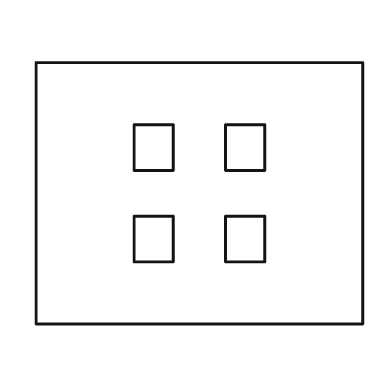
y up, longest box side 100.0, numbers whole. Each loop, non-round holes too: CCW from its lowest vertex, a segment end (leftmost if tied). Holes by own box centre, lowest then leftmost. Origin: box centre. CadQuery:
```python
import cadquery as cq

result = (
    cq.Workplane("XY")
    .moveTo(-50.0, -40.0)
    .lineTo(50.0, -40.0)
    .lineTo(50.0, 40.0)
    .lineTo(-50.0, 40.0)
    .close()
    .moveTo(-20.0, -21.0)
    .lineTo(-8.0, -21.0)
    .lineTo(-8.0, -7.0)
    .lineTo(-20.0, -7.0)
    .close()
    .moveTo(8.0, -21.0)
    .lineTo(20.0, -21.0)
    .lineTo(20.0, -7.0)
    .lineTo(8.0, -7.0)
    .close()
    .moveTo(-20.0, 7.0)
    .lineTo(-8.0, 7.0)
    .lineTo(-8.0, 21.0)
    .lineTo(-20.0, 21.0)
    .close()
    .moveTo(8.0, 7.0)
    .lineTo(20.0, 7.0)
    .lineTo(20.0, 21.0)
    .lineTo(8.0, 21.0)
    .close()
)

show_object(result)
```